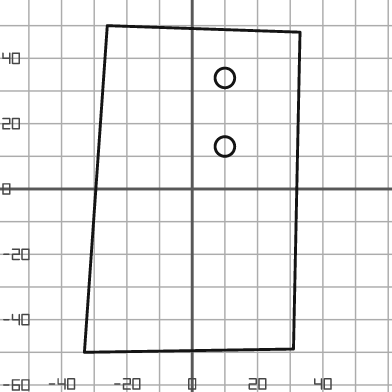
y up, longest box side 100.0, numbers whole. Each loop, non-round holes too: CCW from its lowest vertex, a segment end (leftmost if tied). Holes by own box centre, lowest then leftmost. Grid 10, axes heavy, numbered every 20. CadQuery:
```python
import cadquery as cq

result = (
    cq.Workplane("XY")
    .moveTo(-33.0, -50.0)
    .lineTo(31.0, -49.0)
    .lineTo(33.0, 48.0)
    .lineTo(-26.0, 50.0)
    .close()
    .moveTo(10.0, 13.0)
    .circle(3.0)
    .moveTo(10.0, 34.0)
    .circle(3.0)
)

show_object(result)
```